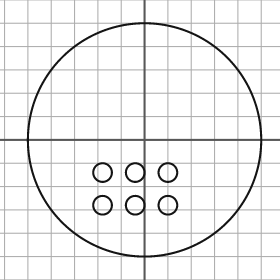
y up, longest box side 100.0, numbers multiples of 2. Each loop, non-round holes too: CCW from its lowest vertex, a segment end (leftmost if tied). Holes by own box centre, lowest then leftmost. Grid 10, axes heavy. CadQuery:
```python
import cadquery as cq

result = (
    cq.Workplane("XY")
    .moveTo(0.0, 0.0)
    .circle(50.0)
    .moveTo(-18.0, -28.0)
    .circle(4.0)
    .moveTo(-4.0, -28.0)
    .circle(4.0)
    .moveTo(10.0, -28.0)
    .circle(4.0)
    .moveTo(-18.0, -14.0)
    .circle(4.0)
    .moveTo(-4.0, -14.0)
    .circle(4.0)
    .moveTo(10.0, -14.0)
    .circle(4.0)
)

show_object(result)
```